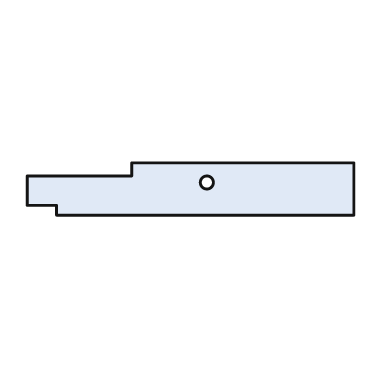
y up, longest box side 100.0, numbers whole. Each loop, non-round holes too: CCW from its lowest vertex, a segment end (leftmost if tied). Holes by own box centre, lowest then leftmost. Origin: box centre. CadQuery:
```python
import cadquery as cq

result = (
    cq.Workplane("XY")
    .moveTo(-41.0, -8.0)
    .lineTo(50.0, -8.0)
    .lineTo(50.0, 8.0)
    .lineTo(-18.0, 8.0)
    .lineTo(-18.0, 4.0)
    .lineTo(-50.0, 4.0)
    .lineTo(-50.0, -5.0)
    .lineTo(-41.0, -5.0)
    .close()
    .moveTo(5.0, 2.0)
    .circle(2.0)
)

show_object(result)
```